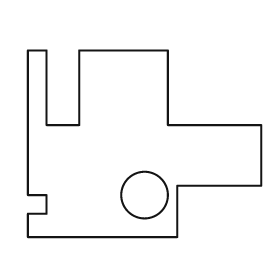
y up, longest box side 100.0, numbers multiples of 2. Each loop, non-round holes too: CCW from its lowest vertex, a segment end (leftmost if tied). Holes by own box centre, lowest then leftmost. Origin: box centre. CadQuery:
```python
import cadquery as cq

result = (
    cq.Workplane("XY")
    .moveTo(-50.0, -40.0)
    .lineTo(14.0, -40.0)
    .lineTo(14.0, -18.0)
    .lineTo(50.0, -18.0)
    .lineTo(50.0, 8.0)
    .lineTo(10.0, 8.0)
    .lineTo(10.0, 40.0)
    .lineTo(-28.0, 40.0)
    .lineTo(-28.0, 8.0)
    .lineTo(-42.0, 8.0)
    .lineTo(-42.0, 40.0)
    .lineTo(-50.0, 40.0)
    .lineTo(-50.0, -22.0)
    .lineTo(-42.0, -22.0)
    .lineTo(-42.0, -30.0)
    .lineTo(-50.0, -30.0)
    .close()
    .moveTo(0.0, -22.0)
    .circle(10.0)
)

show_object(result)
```